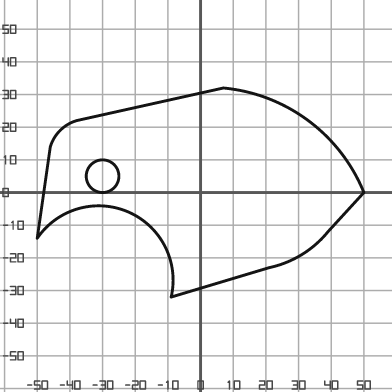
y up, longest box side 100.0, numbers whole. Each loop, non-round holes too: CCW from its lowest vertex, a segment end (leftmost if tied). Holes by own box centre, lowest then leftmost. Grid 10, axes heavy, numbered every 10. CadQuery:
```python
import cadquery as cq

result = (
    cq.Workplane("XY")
    .moveTo(-9.0, -32.0)
    .lineTo(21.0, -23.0)
    .threePointArc((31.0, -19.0), (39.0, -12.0))
    .lineTo(50.0, 0.0)
    .threePointArc((33.0, 22.0), (7.0, 32.0))
    .lineTo(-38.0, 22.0)
    .threePointArc((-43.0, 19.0), (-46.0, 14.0))
    .lineTo(-50.0, -14.0)
    .threePointArc((-22.0, -6.0), (-9.0, -32.0))
    .close()
    .moveTo(-30.0, 5.0)
    .circle(5.0)
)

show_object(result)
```